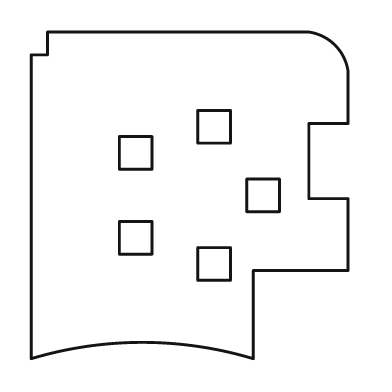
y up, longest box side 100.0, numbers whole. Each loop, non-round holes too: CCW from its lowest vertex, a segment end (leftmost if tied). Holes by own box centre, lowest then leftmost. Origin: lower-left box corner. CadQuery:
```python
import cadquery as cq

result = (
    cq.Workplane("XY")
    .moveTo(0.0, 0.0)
    .threePointArc((34.0, 5.0), (68.0, 0.0))
    .lineTo(68.0, 27.0)
    .lineTo(97.0, 27.0)
    .lineTo(97.0, 49.0)
    .lineTo(85.0, 49.0)
    .lineTo(85.0, 72.0)
    .lineTo(97.0, 72.0)
    .lineTo(97.0, 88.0)
    .threePointArc((93.0, 96.0), (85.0, 100.0))
    .lineTo(5.0, 100.0)
    .lineTo(5.0, 93.0)
    .lineTo(0.0, 93.0)
    .close()
    .moveTo(51.0, 24.0)
    .lineTo(61.0, 24.0)
    .lineTo(61.0, 34.0)
    .lineTo(51.0, 34.0)
    .close()
    .moveTo(27.0, 32.0)
    .lineTo(37.0, 32.0)
    .lineTo(37.0, 42.0)
    .lineTo(27.0, 42.0)
    .close()
    .moveTo(66.0, 45.0)
    .lineTo(76.0, 45.0)
    .lineTo(76.0, 55.0)
    .lineTo(66.0, 55.0)
    .close()
    .moveTo(27.0, 58.0)
    .lineTo(37.0, 58.0)
    .lineTo(37.0, 68.0)
    .lineTo(27.0, 68.0)
    .close()
    .moveTo(51.0, 66.0)
    .lineTo(61.0, 66.0)
    .lineTo(61.0, 76.0)
    .lineTo(51.0, 76.0)
    .close()
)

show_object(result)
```